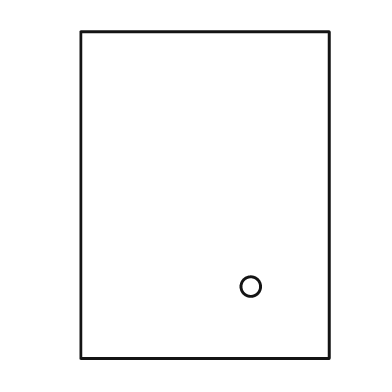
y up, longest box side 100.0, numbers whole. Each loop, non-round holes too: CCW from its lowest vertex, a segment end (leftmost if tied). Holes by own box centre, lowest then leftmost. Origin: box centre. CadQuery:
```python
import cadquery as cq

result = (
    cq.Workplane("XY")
    .moveTo(-38.0, -50.0)
    .lineTo(38.0, -50.0)
    .lineTo(38.0, 50.0)
    .lineTo(-38.0, 50.0)
    .close()
    .moveTo(14.0, -28.0)
    .circle(3.0)
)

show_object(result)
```